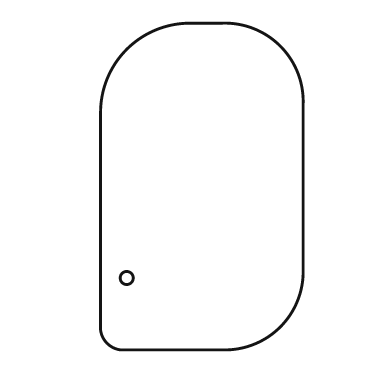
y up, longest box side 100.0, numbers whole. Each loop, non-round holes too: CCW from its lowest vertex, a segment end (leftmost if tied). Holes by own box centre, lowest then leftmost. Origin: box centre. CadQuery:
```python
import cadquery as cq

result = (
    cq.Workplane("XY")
    .moveTo(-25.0, -50.0)
    .lineTo(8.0, -50.0)
    .threePointArc((24.0, -43.0), (31.0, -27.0))
    .lineTo(31.0, 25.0)
    .threePointArc((24.0, 43.0), (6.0, 50.0))
    .lineTo(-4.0, 50.0)
    .threePointArc((-23.0, 42.0), (-31.0, 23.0))
    .lineTo(-31.0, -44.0)
    .threePointArc((-29.0, -48.0), (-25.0, -50.0))
    .close()
    .moveTo(-23.0, -28.0)
    .circle(2.0)
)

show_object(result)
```